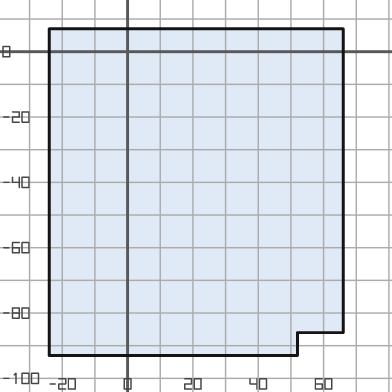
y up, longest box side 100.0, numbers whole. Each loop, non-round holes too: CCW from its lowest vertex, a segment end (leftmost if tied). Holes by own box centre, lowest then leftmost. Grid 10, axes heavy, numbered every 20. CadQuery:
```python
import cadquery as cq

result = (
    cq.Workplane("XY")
    .moveTo(-24.0, -93.0)
    .lineTo(52.0, -93.0)
    .lineTo(52.0, -86.0)
    .lineTo(66.0, -86.0)
    .lineTo(66.0, 7.0)
    .lineTo(-24.0, 7.0)
    .close()
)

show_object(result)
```